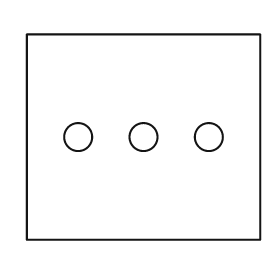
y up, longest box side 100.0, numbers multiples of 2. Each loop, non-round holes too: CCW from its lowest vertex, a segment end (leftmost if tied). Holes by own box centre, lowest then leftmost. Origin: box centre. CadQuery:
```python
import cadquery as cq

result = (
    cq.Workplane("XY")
    .moveTo(-50.0, -44.0)
    .lineTo(50.0, -44.0)
    .lineTo(50.0, 44.0)
    .lineTo(-50.0, 44.0)
    .close()
    .moveTo(-28.0, 0.0)
    .circle(6.0)
    .moveTo(0.0, 0.0)
    .circle(6.0)
    .moveTo(28.0, 0.0)
    .circle(6.0)
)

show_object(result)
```